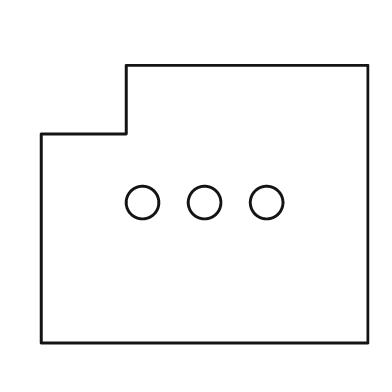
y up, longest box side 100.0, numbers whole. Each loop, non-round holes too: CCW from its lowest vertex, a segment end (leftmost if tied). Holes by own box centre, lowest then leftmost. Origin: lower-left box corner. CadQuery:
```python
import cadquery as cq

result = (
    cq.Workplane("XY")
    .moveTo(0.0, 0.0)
    .lineTo(100.0, 0.0)
    .lineTo(100.0, 85.0)
    .lineTo(26.0, 85.0)
    .lineTo(26.0, 64.0)
    .lineTo(0.0, 64.0)
    .close()
    .moveTo(31.0, 43.0)
    .circle(5.0)
    .moveTo(50.0, 43.0)
    .circle(5.0)
    .moveTo(69.0, 43.0)
    .circle(5.0)
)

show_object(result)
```